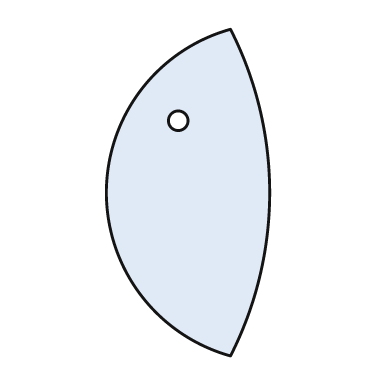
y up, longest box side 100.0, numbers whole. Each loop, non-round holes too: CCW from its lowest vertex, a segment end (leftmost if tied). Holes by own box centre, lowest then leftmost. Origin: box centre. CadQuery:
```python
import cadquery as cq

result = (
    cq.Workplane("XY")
    .moveTo(13.0, -50.0)
    .threePointArc((25.0, 0.0), (13.0, 50.0))
    .threePointArc((-25.0, 0.0), (13.0, -50.0))
    .close()
    .moveTo(-3.0, 22.0)
    .circle(3.0)
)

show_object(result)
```